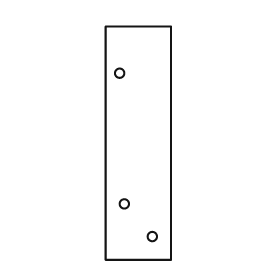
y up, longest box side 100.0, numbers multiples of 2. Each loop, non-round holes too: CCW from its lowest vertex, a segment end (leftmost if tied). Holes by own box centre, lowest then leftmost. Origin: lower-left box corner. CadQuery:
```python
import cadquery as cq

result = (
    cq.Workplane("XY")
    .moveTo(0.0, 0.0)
    .lineTo(28.0, 0.0)
    .lineTo(28.0, 100.0)
    .lineTo(0.0, 100.0)
    .close()
    .moveTo(20.0, 10.0)
    .circle(2.0)
    .moveTo(8.0, 24.0)
    .circle(2.0)
    .moveTo(6.0, 80.0)
    .circle(2.0)
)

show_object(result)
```